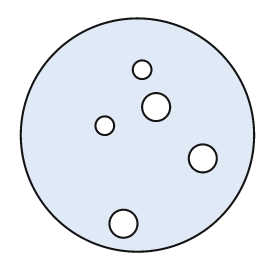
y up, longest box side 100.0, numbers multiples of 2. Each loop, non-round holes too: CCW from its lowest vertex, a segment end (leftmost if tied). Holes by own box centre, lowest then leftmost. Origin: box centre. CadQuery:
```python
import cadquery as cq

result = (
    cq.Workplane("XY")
    .moveTo(0.0, 0.0)
    .circle(50.0)
    .moveTo(-6.0, -38.0)
    .circle(6.0)
    .moveTo(28.0, -10.0)
    .circle(6.0)
    .moveTo(-14.0, 4.0)
    .circle(4.0)
    .moveTo(8.0, 12.0)
    .circle(6.0)
    .moveTo(2.0, 28.0)
    .circle(4.0)
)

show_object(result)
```